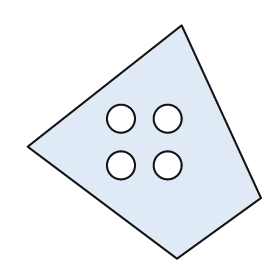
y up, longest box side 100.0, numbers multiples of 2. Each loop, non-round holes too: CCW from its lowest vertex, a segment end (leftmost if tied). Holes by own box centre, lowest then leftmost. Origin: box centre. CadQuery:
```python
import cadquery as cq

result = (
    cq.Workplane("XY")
    .moveTo(14.0, -50.0)
    .lineTo(50.0, -24.0)
    .lineTo(16.0, 50.0)
    .lineTo(-50.0, -2.0)
    .close()
    .moveTo(-10.0, -10.0)
    .circle(6.0)
    .moveTo(10.0, -10.0)
    .circle(6.0)
    .moveTo(-10.0, 10.0)
    .circle(6.0)
    .moveTo(10.0, 10.0)
    .circle(6.0)
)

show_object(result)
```